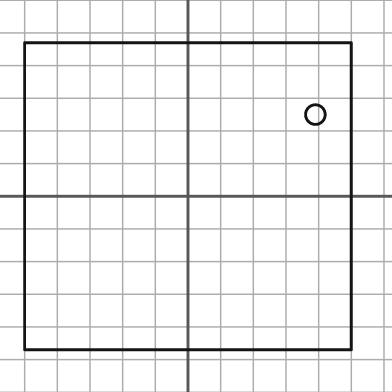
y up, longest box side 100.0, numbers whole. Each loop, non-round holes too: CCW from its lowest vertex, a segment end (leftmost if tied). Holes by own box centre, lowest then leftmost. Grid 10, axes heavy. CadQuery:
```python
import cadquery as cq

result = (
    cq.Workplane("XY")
    .moveTo(-50.0, -47.0)
    .lineTo(50.0, -47.0)
    .lineTo(50.0, 47.0)
    .lineTo(-50.0, 47.0)
    .close()
    .moveTo(39.0, 25.0)
    .circle(3.0)
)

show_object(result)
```